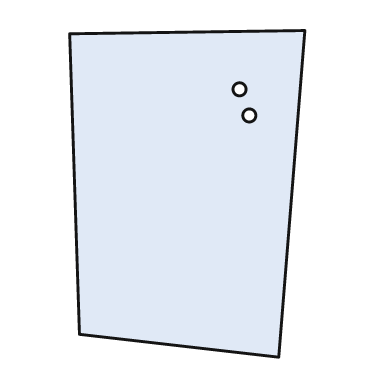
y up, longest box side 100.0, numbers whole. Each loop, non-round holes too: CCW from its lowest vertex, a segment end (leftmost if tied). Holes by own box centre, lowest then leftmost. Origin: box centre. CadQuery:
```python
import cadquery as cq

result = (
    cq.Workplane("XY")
    .moveTo(28.0, -50.0)
    .lineTo(36.0, 50.0)
    .lineTo(-36.0, 49.0)
    .lineTo(-33.0, -43.0)
    .close()
    .moveTo(19.0, 24.0)
    .circle(2.0)
    .moveTo(16.0, 32.0)
    .circle(2.0)
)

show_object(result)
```